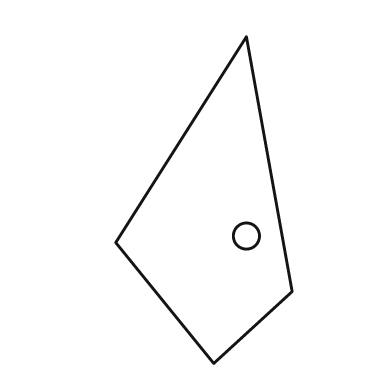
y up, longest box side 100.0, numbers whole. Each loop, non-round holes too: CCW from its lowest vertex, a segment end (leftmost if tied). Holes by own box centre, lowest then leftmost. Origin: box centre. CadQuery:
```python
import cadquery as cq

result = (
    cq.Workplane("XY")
    .moveTo(3.0, -50.0)
    .lineTo(27.0, -28.0)
    .lineTo(13.0, 50.0)
    .lineTo(-27.0, -13.0)
    .close()
    .moveTo(13.0, -11.0)
    .circle(4.0)
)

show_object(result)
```